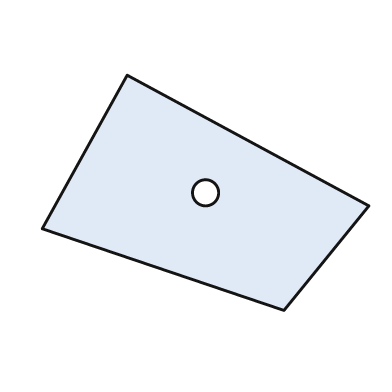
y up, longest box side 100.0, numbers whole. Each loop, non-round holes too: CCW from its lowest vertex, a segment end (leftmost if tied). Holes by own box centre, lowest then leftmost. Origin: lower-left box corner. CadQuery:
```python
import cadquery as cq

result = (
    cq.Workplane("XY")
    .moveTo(74.0, 0.0)
    .lineTo(100.0, 32.0)
    .lineTo(26.0, 72.0)
    .lineTo(0.0, 25.0)
    .close()
    .moveTo(50.0, 36.0)
    .circle(4.0)
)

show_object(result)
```